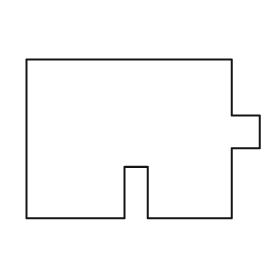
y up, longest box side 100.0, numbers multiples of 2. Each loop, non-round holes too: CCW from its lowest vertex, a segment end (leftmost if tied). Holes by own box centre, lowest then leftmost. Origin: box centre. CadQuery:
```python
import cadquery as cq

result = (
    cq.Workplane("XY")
    .moveTo(-50.0, -34.0)
    .lineTo(-8.0, -34.0)
    .lineTo(-8.0, -12.0)
    .lineTo(2.0, -12.0)
    .lineTo(2.0, -34.0)
    .lineTo(38.0, -34.0)
    .lineTo(38.0, -4.0)
    .lineTo(50.0, -4.0)
    .lineTo(50.0, 10.0)
    .lineTo(38.0, 10.0)
    .lineTo(38.0, 34.0)
    .lineTo(-50.0, 34.0)
    .close()
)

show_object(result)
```